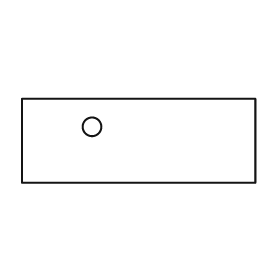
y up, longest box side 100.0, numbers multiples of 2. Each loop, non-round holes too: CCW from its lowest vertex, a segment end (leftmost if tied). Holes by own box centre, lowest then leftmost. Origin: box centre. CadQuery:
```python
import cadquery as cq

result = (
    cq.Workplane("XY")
    .moveTo(-50.0, -18.0)
    .lineTo(50.0, -18.0)
    .lineTo(50.0, 18.0)
    .lineTo(-50.0, 18.0)
    .close()
    .moveTo(-20.0, 6.0)
    .circle(4.0)
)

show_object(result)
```